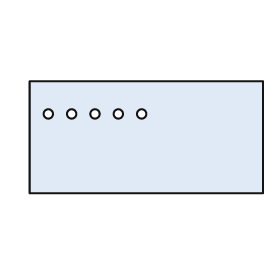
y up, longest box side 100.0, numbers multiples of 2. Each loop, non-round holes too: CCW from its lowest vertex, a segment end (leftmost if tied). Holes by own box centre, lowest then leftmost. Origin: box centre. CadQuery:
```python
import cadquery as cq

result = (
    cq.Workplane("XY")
    .moveTo(-50.0, -24.0)
    .lineTo(50.0, -24.0)
    .lineTo(50.0, 24.0)
    .lineTo(-50.0, 24.0)
    .close()
    .moveTo(-42.0, 10.0)
    .circle(2.0)
    .moveTo(-32.0, 10.0)
    .circle(2.0)
    .moveTo(-22.0, 10.0)
    .circle(2.0)
    .moveTo(-12.0, 10.0)
    .circle(2.0)
    .moveTo(-2.0, 10.0)
    .circle(2.0)
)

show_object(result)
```